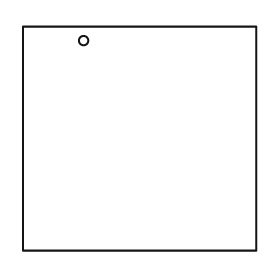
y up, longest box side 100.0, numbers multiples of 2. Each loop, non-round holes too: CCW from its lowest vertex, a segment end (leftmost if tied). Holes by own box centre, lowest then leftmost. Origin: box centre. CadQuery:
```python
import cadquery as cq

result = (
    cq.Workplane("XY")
    .moveTo(-50.0, -48.0)
    .lineTo(50.0, -48.0)
    .lineTo(50.0, 48.0)
    .lineTo(-50.0, 48.0)
    .close()
    .moveTo(-24.0, 42.0)
    .circle(2.0)
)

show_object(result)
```